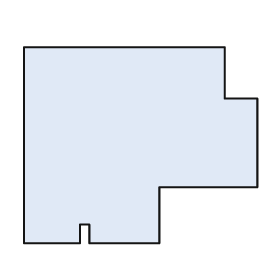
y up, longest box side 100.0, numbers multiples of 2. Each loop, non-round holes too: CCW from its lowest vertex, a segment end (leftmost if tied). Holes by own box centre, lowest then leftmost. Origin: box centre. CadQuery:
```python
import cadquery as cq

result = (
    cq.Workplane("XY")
    .moveTo(-50.0, -42.0)
    .lineTo(-26.0, -42.0)
    .lineTo(-26.0, -34.0)
    .lineTo(-22.0, -34.0)
    .lineTo(-22.0, -42.0)
    .lineTo(8.0, -42.0)
    .lineTo(8.0, -18.0)
    .lineTo(50.0, -18.0)
    .lineTo(50.0, 20.0)
    .lineTo(36.0, 20.0)
    .lineTo(36.0, 42.0)
    .lineTo(-50.0, 42.0)
    .close()
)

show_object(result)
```